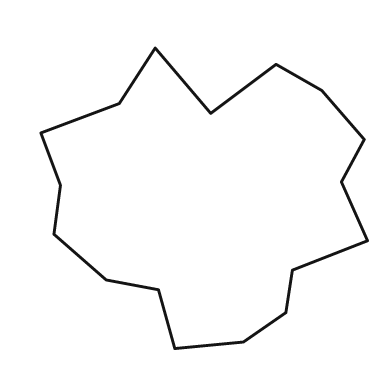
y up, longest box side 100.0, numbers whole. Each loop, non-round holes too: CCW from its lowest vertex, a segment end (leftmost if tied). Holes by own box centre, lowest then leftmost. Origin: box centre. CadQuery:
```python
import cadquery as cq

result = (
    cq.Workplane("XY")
    .moveTo(-9.0, -46.0)
    .lineTo(12.0, -44.0)
    .lineTo(25.0, -35.0)
    .lineTo(27.0, -22.0)
    .lineTo(50.0, -13.0)
    .lineTo(42.0, 5.0)
    .lineTo(49.0, 18.0)
    .lineTo(36.0, 33.0)
    .lineTo(22.0, 41.0)
    .lineTo(2.0, 26.0)
    .lineTo(-15.0, 46.0)
    .lineTo(-26.0, 29.0)
    .lineTo(-50.0, 20.0)
    .lineTo(-44.0, 4.0)
    .lineTo(-46.0, -11.0)
    .lineTo(-30.0, -25.0)
    .lineTo(-14.0, -28.0)
    .close()
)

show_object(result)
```